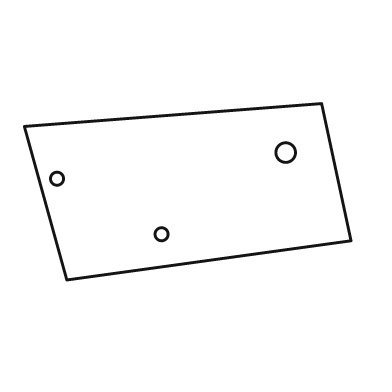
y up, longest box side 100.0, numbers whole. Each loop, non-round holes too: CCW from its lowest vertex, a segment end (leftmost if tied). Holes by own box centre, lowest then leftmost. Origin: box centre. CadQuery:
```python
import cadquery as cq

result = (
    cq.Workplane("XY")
    .moveTo(-37.0, -27.0)
    .lineTo(50.0, -15.0)
    .lineTo(41.0, 27.0)
    .lineTo(-50.0, 20.0)
    .close()
    .moveTo(-8.0, -13.0)
    .circle(2.0)
    .moveTo(-40.0, 4.0)
    .circle(2.0)
    .moveTo(30.0, 12.0)
    .circle(3.0)
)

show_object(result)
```